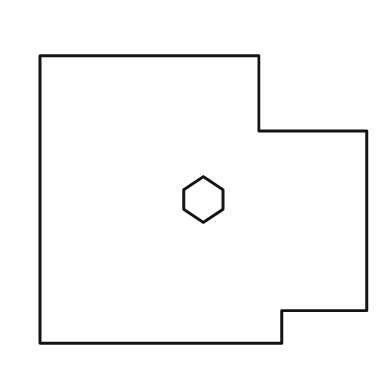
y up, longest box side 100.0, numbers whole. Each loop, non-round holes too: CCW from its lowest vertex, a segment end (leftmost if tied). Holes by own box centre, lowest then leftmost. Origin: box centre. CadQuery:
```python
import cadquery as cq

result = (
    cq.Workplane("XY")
    .moveTo(-50.0, -44.0)
    .lineTo(24.0, -44.0)
    .lineTo(24.0, -34.0)
    .lineTo(50.0, -34.0)
    .lineTo(50.0, 21.0)
    .lineTo(17.0, 21.0)
    .lineTo(17.0, 44.0)
    .lineTo(-50.0, 44.0)
    .close()
    .moveTo(0.0, -7.0)
    .lineTo(6.0, -3.0)
    .lineTo(6.0, 3.0)
    .lineTo(0.0, 7.0)
    .lineTo(-6.0, 3.0)
    .lineTo(-6.0, -3.0)
    .close()
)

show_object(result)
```